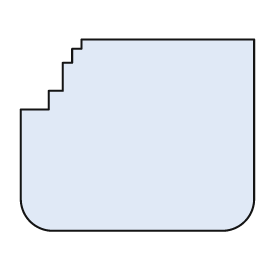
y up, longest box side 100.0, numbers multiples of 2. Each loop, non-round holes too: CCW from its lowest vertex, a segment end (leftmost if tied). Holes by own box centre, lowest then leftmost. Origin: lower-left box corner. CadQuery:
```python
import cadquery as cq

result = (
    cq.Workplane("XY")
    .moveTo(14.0, 0.0)
    .lineTo(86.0, 0.0)
    .threePointArc((96.0, 4.0), (100.0, 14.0))
    .lineTo(100.0, 82.0)
    .lineTo(26.0, 82.0)
    .lineTo(26.0, 78.0)
    .lineTo(22.0, 78.0)
    .lineTo(22.0, 72.0)
    .lineTo(18.0, 72.0)
    .lineTo(18.0, 60.0)
    .lineTo(12.0, 60.0)
    .lineTo(12.0, 52.0)
    .lineTo(0.0, 52.0)
    .lineTo(0.0, 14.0)
    .threePointArc((4.0, 4.0), (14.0, 0.0))
    .close()
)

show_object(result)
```